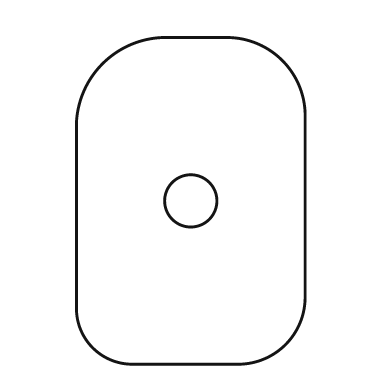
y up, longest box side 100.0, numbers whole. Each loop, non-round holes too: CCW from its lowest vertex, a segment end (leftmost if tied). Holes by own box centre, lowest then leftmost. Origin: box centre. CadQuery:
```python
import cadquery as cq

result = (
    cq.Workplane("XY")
    .moveTo(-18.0, -50.0)
    .lineTo(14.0, -50.0)
    .threePointArc((29.0, -44.0), (35.0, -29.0))
    .lineTo(35.0, 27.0)
    .threePointArc((28.0, 43.0), (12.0, 50.0))
    .lineTo(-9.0, 50.0)
    .threePointArc((-27.0, 42.0), (-35.0, 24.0))
    .lineTo(-35.0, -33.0)
    .threePointArc((-30.0, -45.0), (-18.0, -50.0))
    .close()
    .moveTo(0.0, 0.0)
    .circle(8.0)
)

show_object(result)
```